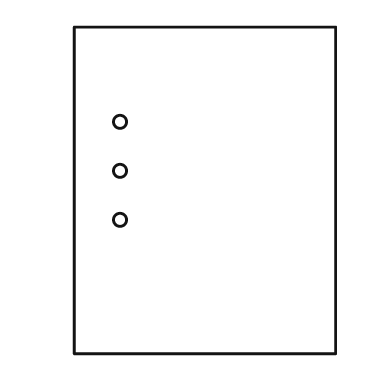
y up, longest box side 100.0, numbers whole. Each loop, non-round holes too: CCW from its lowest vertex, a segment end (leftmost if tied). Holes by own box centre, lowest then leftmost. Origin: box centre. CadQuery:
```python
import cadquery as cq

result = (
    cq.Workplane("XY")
    .moveTo(-40.0, -50.0)
    .lineTo(40.0, -50.0)
    .lineTo(40.0, 50.0)
    .lineTo(-40.0, 50.0)
    .close()
    .moveTo(-26.0, -9.0)
    .circle(2.0)
    .moveTo(-26.0, 6.0)
    .circle(2.0)
    .moveTo(-26.0, 21.0)
    .circle(2.0)
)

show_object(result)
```